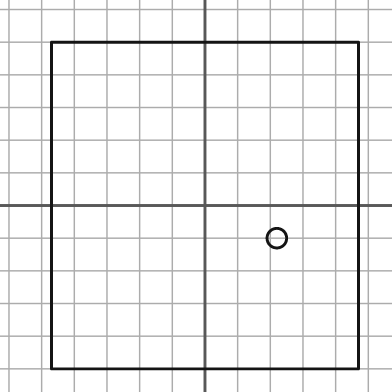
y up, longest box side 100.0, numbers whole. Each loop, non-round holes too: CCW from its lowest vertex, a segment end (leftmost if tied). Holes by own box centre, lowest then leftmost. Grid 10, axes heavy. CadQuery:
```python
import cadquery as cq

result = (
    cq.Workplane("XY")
    .moveTo(-47.0, -50.0)
    .lineTo(47.0, -50.0)
    .lineTo(47.0, 50.0)
    .lineTo(-47.0, 50.0)
    .close()
    .moveTo(22.0, -10.0)
    .circle(3.0)
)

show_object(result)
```